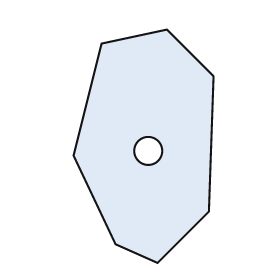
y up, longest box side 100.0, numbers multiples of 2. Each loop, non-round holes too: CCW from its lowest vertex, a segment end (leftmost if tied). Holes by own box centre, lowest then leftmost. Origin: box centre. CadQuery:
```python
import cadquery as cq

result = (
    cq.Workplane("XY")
    .moveTo(6.0, -50.0)
    .lineTo(28.0, -28.0)
    .lineTo(30.0, 30.0)
    .lineTo(10.0, 50.0)
    .lineTo(-18.0, 44.0)
    .lineTo(-30.0, -4.0)
    .lineTo(-12.0, -42.0)
    .close()
    .moveTo(2.0, -2.0)
    .circle(6.0)
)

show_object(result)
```